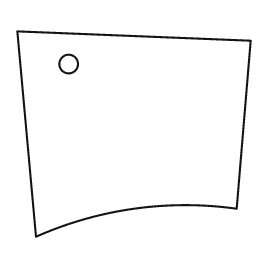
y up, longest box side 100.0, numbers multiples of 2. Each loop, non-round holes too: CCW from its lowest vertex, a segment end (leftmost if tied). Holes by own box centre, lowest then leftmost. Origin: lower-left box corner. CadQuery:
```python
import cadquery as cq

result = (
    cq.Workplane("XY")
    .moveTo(8.0, 0.0)
    .threePointArc((50.0, 12.0), (94.0, 12.0))
    .lineTo(100.0, 84.0)
    .lineTo(0.0, 88.0)
    .close()
    .moveTo(22.0, 74.0)
    .circle(4.0)
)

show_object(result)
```